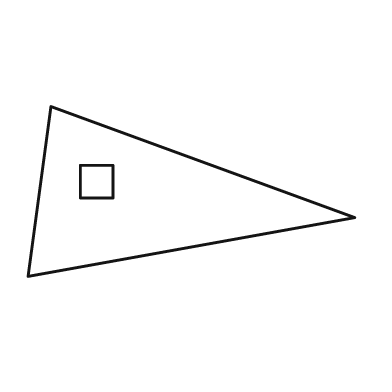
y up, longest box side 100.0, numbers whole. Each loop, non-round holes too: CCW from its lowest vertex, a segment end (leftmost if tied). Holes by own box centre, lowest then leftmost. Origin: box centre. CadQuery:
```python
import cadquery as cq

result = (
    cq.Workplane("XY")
    .moveTo(-50.0, -26.0)
    .lineTo(50.0, -8.0)
    .lineTo(-43.0, 26.0)
    .close()
    .moveTo(-34.0, -2.0)
    .lineTo(-24.0, -2.0)
    .lineTo(-24.0, 8.0)
    .lineTo(-34.0, 8.0)
    .close()
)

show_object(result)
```